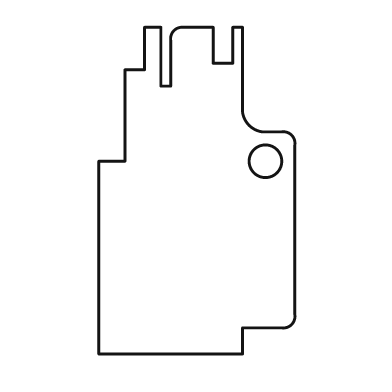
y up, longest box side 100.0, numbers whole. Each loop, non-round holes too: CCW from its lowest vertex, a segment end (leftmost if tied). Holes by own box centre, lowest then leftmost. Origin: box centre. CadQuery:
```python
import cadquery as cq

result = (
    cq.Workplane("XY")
    .moveTo(-30.0, -50.0)
    .lineTo(14.0, -50.0)
    .lineTo(14.0, -42.0)
    .lineTo(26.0, -42.0)
    .threePointArc((29.0, -41.0), (30.0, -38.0))
    .lineTo(30.0, 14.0)
    .threePointArc((29.0, 17.0), (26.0, 18.0))
    .lineTo(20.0, 18.0)
    .threePointArc((16.0, 20.0), (14.0, 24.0))
    .lineTo(14.0, 50.0)
    .lineTo(11.0, 50.0)
    .lineTo(11.0, 39.0)
    .lineTo(5.0, 39.0)
    .lineTo(5.0, 50.0)
    .lineTo(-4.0, 50.0)
    .threePointArc((-7.0, 49.0), (-8.0, 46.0))
    .lineTo(-8.0, 32.0)
    .lineTo(-11.0, 32.0)
    .lineTo(-11.0, 50.0)
    .lineTo(-16.0, 50.0)
    .lineTo(-16.0, 37.0)
    .lineTo(-22.0, 37.0)
    .lineTo(-22.0, 9.0)
    .lineTo(-30.0, 9.0)
    .close()
    .moveTo(21.0, 9.0)
    .circle(5.0)
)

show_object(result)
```